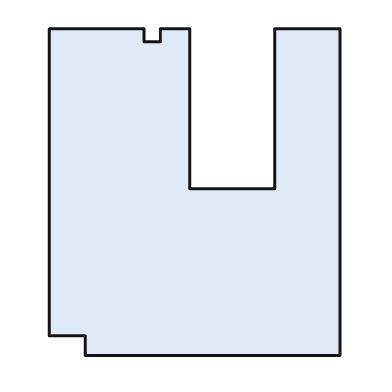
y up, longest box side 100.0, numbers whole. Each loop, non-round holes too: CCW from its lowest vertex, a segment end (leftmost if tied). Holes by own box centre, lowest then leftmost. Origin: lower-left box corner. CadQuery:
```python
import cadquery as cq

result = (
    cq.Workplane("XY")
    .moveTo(11.0, 0.0)
    .lineTo(89.0, 0.0)
    .lineTo(89.0, 100.0)
    .lineTo(69.0, 100.0)
    .lineTo(69.0, 51.0)
    .lineTo(43.0, 51.0)
    .lineTo(43.0, 100.0)
    .lineTo(34.0, 100.0)
    .lineTo(34.0, 96.0)
    .lineTo(29.0, 96.0)
    .lineTo(29.0, 100.0)
    .lineTo(0.0, 100.0)
    .lineTo(0.0, 6.0)
    .lineTo(11.0, 6.0)
    .close()
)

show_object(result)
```